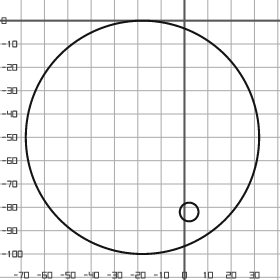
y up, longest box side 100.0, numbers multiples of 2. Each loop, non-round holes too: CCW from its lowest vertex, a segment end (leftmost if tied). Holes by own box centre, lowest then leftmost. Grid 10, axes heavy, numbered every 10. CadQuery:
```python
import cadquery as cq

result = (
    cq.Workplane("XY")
    .moveTo(-18.0, -50.0)
    .circle(50.0)
    .moveTo(2.0, -82.0)
    .circle(4.0)
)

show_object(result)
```